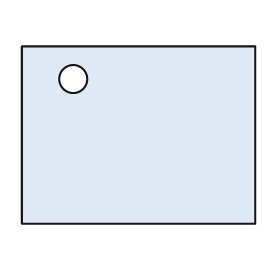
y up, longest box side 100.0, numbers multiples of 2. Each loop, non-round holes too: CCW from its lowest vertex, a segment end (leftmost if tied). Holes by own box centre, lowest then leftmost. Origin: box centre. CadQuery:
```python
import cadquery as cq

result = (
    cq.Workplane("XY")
    .moveTo(-50.0, -38.0)
    .lineTo(50.0, -38.0)
    .lineTo(50.0, 38.0)
    .lineTo(-50.0, 38.0)
    .close()
    .moveTo(-28.0, 24.0)
    .circle(6.0)
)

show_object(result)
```